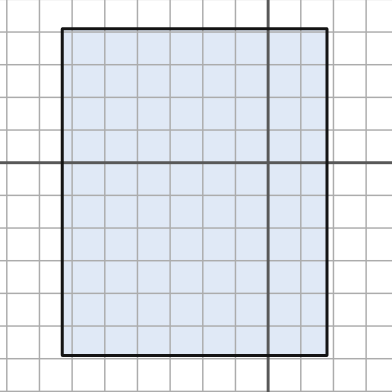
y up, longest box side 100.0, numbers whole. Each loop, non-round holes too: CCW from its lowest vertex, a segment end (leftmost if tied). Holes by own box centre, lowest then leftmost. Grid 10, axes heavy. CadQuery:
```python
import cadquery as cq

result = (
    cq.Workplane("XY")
    .moveTo(-63.0, -59.0)
    .lineTo(18.0, -59.0)
    .lineTo(18.0, 41.0)
    .lineTo(-63.0, 41.0)
    .close()
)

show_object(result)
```